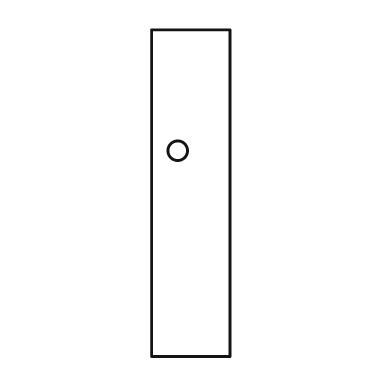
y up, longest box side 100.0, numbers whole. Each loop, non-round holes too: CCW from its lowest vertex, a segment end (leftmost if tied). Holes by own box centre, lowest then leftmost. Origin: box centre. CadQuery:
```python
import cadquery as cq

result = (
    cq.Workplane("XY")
    .moveTo(-12.0, -50.0)
    .lineTo(12.0, -50.0)
    .lineTo(12.0, 50.0)
    .lineTo(-12.0, 50.0)
    .close()
    .moveTo(-4.0, 13.0)
    .circle(3.0)
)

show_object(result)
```